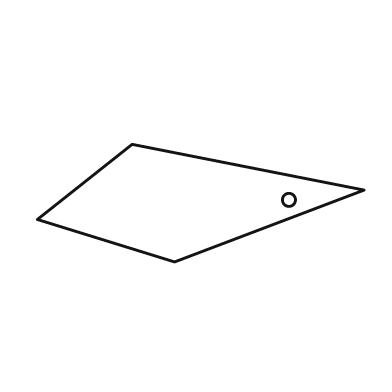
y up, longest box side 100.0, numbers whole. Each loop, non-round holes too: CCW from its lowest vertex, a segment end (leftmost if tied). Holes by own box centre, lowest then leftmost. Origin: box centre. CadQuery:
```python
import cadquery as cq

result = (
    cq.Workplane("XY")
    .moveTo(-8.0, -18.0)
    .lineTo(50.0, 4.0)
    .lineTo(-21.0, 18.0)
    .lineTo(-50.0, -5.0)
    .close()
    .moveTo(27.0, 1.0)
    .circle(2.0)
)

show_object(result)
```